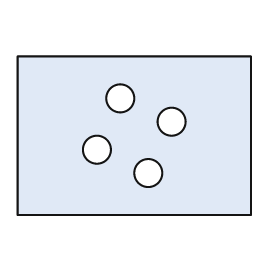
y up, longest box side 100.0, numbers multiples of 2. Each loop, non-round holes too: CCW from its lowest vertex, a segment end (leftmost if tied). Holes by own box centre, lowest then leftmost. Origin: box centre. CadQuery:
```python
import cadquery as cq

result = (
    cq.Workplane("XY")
    .moveTo(-50.0, -34.0)
    .lineTo(50.0, -34.0)
    .lineTo(50.0, 34.0)
    .lineTo(-50.0, 34.0)
    .close()
    .moveTo(6.0, -16.0)
    .circle(6.0)
    .moveTo(-16.0, -6.0)
    .circle(6.0)
    .moveTo(16.0, 6.0)
    .circle(6.0)
    .moveTo(-6.0, 16.0)
    .circle(6.0)
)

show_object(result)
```